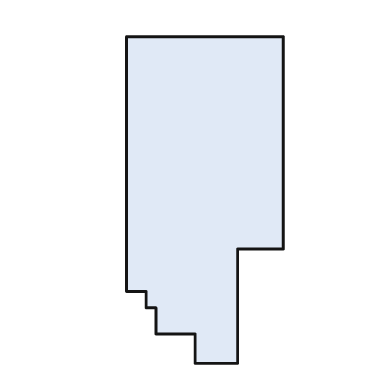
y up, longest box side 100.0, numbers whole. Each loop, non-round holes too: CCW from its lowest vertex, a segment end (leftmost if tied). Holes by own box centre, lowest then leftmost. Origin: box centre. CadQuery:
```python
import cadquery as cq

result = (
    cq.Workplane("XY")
    .moveTo(-3.0, -50.0)
    .lineTo(10.0, -50.0)
    .lineTo(10.0, -15.0)
    .lineTo(24.0, -15.0)
    .lineTo(24.0, 50.0)
    .lineTo(-24.0, 50.0)
    .lineTo(-24.0, -28.0)
    .lineTo(-18.0, -28.0)
    .lineTo(-18.0, -33.0)
    .lineTo(-15.0, -33.0)
    .lineTo(-15.0, -41.0)
    .lineTo(-3.0, -41.0)
    .close()
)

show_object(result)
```